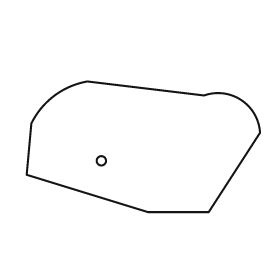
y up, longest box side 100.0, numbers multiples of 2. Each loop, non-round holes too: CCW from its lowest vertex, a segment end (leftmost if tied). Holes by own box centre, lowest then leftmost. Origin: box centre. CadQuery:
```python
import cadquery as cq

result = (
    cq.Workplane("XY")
    .moveTo(2.0, -28.0)
    .lineTo(28.0, -28.0)
    .lineTo(50.0, 6.0)
    .threePointArc((42.0, 20.0), (26.0, 22.0))
    .lineTo(-24.0, 28.0)
    .threePointArc((-38.0, 22.0), (-48.0, 10.0))
    .lineTo(-50.0, -12.0)
    .close()
    .moveTo(-18.0, -6.0)
    .circle(2.0)
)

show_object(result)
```